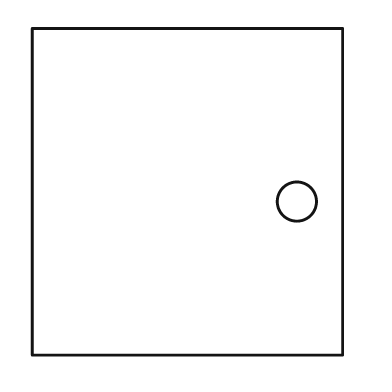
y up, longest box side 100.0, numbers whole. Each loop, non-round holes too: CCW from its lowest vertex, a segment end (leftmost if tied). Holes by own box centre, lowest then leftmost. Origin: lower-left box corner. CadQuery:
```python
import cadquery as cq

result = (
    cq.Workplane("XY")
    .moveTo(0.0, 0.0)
    .lineTo(95.0, 0.0)
    .lineTo(95.0, 100.0)
    .lineTo(0.0, 100.0)
    .close()
    .moveTo(81.0, 47.0)
    .circle(6.0)
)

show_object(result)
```